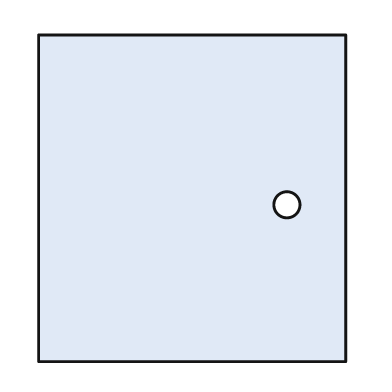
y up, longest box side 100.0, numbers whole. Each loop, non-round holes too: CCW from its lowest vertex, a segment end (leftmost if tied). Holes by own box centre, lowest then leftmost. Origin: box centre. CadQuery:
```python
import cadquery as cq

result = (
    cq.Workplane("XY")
    .moveTo(-47.0, -50.0)
    .lineTo(47.0, -50.0)
    .lineTo(47.0, 50.0)
    .lineTo(-47.0, 50.0)
    .close()
    .moveTo(29.0, -2.0)
    .circle(4.0)
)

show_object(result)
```